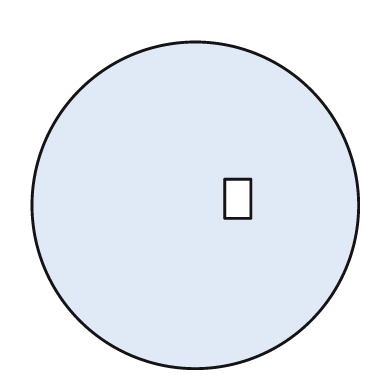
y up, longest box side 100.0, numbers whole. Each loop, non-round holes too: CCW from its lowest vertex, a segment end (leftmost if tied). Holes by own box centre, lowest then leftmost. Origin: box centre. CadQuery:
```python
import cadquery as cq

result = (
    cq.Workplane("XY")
    .moveTo(0.0, 0.0)
    .circle(50.0)
    .moveTo(9.0, -4.0)
    .lineTo(17.0, -4.0)
    .lineTo(17.0, 8.0)
    .lineTo(9.0, 8.0)
    .close()
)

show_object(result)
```